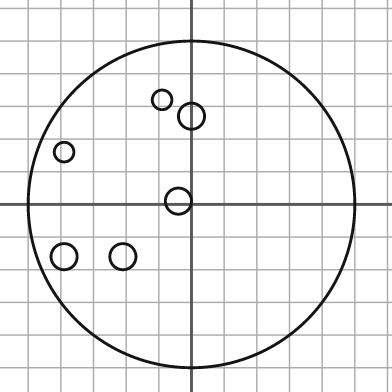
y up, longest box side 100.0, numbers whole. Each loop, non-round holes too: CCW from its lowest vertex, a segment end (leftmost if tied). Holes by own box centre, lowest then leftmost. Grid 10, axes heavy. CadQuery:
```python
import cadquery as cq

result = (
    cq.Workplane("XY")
    .moveTo(0.0, 0.0)
    .circle(50.0)
    .moveTo(-39.0, -16.0)
    .circle(4.0)
    .moveTo(-21.0, -16.0)
    .circle(4.0)
    .moveTo(-4.0, 1.0)
    .circle(4.0)
    .moveTo(-39.0, 16.0)
    .circle(3.0)
    .moveTo(0.0, 27.0)
    .circle(4.0)
    .moveTo(-9.0, 32.0)
    .circle(3.0)
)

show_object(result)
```